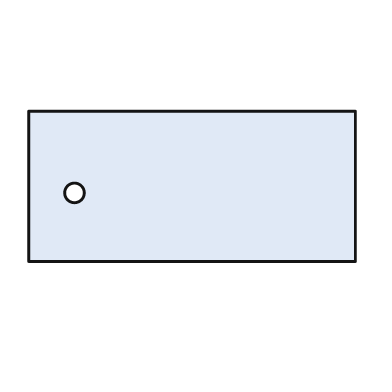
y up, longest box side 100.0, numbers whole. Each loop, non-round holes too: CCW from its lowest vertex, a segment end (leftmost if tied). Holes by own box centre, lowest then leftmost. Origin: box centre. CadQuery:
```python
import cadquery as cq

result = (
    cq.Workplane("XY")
    .moveTo(-50.0, -23.0)
    .lineTo(50.0, -23.0)
    .lineTo(50.0, 23.0)
    .lineTo(-50.0, 23.0)
    .close()
    .moveTo(-36.0, -2.0)
    .circle(3.0)
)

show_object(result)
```